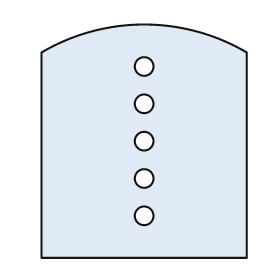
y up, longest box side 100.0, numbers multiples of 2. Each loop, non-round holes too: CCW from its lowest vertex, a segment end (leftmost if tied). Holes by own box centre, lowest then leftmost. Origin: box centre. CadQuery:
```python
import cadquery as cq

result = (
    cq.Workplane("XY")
    .moveTo(-44.0, -50.0)
    .lineTo(44.0, -50.0)
    .lineTo(44.0, 38.0)
    .threePointArc((0.0, 50.0), (-44.0, 38.0))
    .close()
    .moveTo(0.0, -32.0)
    .circle(4.0)
    .moveTo(0.0, -16.0)
    .circle(4.0)
    .moveTo(0.0, 0.0)
    .circle(4.0)
    .moveTo(0.0, 16.0)
    .circle(4.0)
    .moveTo(0.0, 32.0)
    .circle(4.0)
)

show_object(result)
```